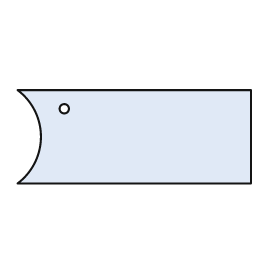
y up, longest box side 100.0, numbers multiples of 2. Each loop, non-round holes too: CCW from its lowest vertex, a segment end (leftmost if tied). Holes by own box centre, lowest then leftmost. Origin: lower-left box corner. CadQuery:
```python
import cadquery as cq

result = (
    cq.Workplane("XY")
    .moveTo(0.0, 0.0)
    .lineTo(100.0, 0.0)
    .lineTo(100.0, 40.0)
    .lineTo(0.0, 40.0)
    .threePointArc((10.0, 20.0), (0.0, 0.0))
    .close()
    .moveTo(20.0, 32.0)
    .circle(2.0)
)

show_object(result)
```